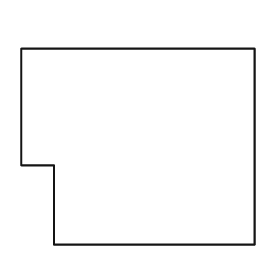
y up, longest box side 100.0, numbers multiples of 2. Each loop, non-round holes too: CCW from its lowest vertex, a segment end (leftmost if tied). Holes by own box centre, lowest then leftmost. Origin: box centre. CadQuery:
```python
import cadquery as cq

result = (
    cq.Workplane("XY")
    .moveTo(-36.0, -42.0)
    .lineTo(50.0, -42.0)
    .lineTo(50.0, 42.0)
    .lineTo(-50.0, 42.0)
    .lineTo(-50.0, -8.0)
    .lineTo(-36.0, -8.0)
    .close()
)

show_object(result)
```